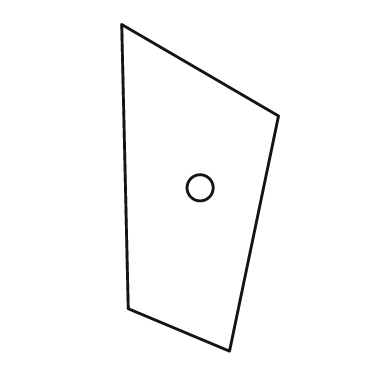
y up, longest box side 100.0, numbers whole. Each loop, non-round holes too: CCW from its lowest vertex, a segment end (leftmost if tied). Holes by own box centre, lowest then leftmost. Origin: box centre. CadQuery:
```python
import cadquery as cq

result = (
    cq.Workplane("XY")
    .moveTo(9.0, -50.0)
    .lineTo(24.0, 22.0)
    .lineTo(-24.0, 50.0)
    .lineTo(-22.0, -37.0)
    .close()
    .moveTo(0.0, 0.0)
    .circle(4.0)
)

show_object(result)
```